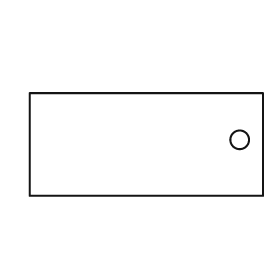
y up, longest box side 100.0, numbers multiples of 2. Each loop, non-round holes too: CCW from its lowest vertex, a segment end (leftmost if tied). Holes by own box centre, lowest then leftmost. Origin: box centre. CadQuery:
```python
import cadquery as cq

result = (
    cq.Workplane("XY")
    .moveTo(-50.0, -22.0)
    .lineTo(50.0, -22.0)
    .lineTo(50.0, 22.0)
    .lineTo(-50.0, 22.0)
    .close()
    .moveTo(40.0, 2.0)
    .circle(4.0)
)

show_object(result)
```